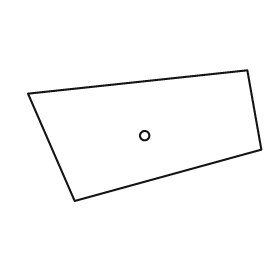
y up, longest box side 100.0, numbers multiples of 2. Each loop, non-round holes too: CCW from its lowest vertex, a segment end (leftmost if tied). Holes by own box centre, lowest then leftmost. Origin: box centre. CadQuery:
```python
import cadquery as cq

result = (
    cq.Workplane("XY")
    .moveTo(-30.0, -28.0)
    .lineTo(50.0, -6.0)
    .lineTo(44.0, 28.0)
    .lineTo(-50.0, 18.0)
    .close()
    .moveTo(0.0, 0.0)
    .circle(2.0)
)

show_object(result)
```